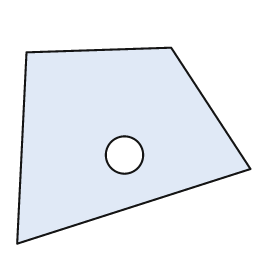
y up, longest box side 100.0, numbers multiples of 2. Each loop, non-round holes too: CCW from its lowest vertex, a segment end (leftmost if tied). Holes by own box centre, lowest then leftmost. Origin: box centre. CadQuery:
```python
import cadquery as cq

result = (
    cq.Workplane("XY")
    .moveTo(-50.0, -42.0)
    .lineTo(50.0, -10.0)
    .lineTo(16.0, 42.0)
    .lineTo(-46.0, 40.0)
    .close()
    .moveTo(-4.0, -4.0)
    .circle(8.0)
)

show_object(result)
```